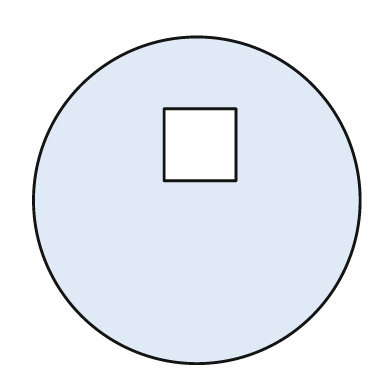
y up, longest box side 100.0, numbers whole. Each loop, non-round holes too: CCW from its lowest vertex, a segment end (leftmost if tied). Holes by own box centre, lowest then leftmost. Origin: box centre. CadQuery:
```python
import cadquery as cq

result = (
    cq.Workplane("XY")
    .moveTo(0.0, 0.0)
    .circle(50.0)
    .moveTo(-10.0, 6.0)
    .lineTo(12.0, 6.0)
    .lineTo(12.0, 28.0)
    .lineTo(-10.0, 28.0)
    .close()
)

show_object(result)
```